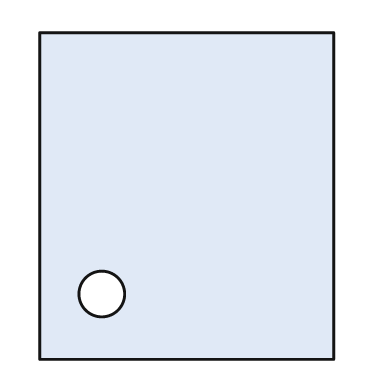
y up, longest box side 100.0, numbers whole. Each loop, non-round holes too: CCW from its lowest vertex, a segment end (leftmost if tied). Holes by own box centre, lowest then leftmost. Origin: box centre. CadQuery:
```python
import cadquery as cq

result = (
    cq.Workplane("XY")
    .moveTo(-45.0, -50.0)
    .lineTo(45.0, -50.0)
    .lineTo(45.0, 50.0)
    .lineTo(-45.0, 50.0)
    .close()
    .moveTo(-26.0, -30.0)
    .circle(7.0)
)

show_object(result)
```